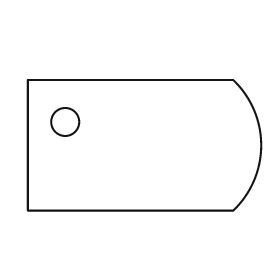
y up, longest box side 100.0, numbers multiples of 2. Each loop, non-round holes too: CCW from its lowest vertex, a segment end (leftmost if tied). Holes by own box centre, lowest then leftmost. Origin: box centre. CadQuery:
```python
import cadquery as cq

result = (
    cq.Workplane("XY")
    .moveTo(-50.0, -28.0)
    .lineTo(38.0, -28.0)
    .threePointArc((50.0, 0.0), (38.0, 28.0))
    .lineTo(-50.0, 28.0)
    .close()
    .moveTo(-34.0, 10.0)
    .circle(6.0)
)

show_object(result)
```